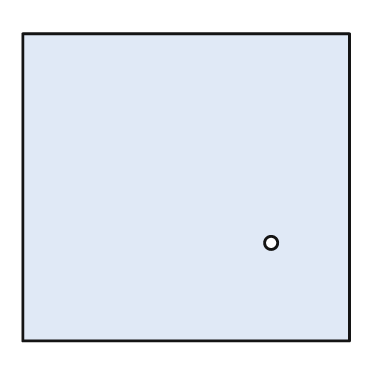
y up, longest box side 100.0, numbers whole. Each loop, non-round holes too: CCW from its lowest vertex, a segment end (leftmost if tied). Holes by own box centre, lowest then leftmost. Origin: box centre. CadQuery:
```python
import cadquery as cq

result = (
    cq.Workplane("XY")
    .moveTo(-50.0, -47.0)
    .lineTo(50.0, -47.0)
    .lineTo(50.0, 47.0)
    .lineTo(-50.0, 47.0)
    .close()
    .moveTo(26.0, -17.0)
    .circle(2.0)
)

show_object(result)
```